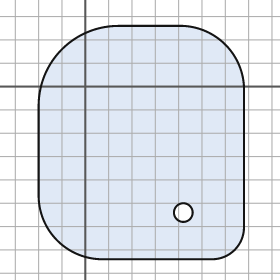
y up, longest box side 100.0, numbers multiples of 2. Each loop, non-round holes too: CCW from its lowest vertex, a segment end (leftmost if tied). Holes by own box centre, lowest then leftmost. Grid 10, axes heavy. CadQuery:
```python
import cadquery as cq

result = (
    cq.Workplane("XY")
    .moveTo(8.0, -74.0)
    .lineTo(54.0, -74.0)
    .threePointArc((64.0, -70.0), (68.0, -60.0))
    .lineTo(68.0, 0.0)
    .threePointArc((60.0, 18.0), (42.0, 26.0))
    .lineTo(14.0, 26.0)
    .threePointArc((-10.0, 16.0), (-20.0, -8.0))
    .lineTo(-20.0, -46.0)
    .threePointArc((-12.0, -66.0), (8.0, -74.0))
    .close()
    .moveTo(42.0, -54.0)
    .circle(4.0)
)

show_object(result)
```